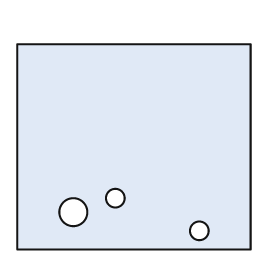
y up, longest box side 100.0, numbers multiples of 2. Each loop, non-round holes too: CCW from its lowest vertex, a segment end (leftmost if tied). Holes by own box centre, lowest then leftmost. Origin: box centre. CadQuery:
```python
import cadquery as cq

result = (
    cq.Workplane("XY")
    .moveTo(-50.0, -44.0)
    .lineTo(50.0, -44.0)
    .lineTo(50.0, 44.0)
    .lineTo(-50.0, 44.0)
    .close()
    .moveTo(28.0, -36.0)
    .circle(4.0)
    .moveTo(-26.0, -28.0)
    .circle(6.0)
    .moveTo(-8.0, -22.0)
    .circle(4.0)
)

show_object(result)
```